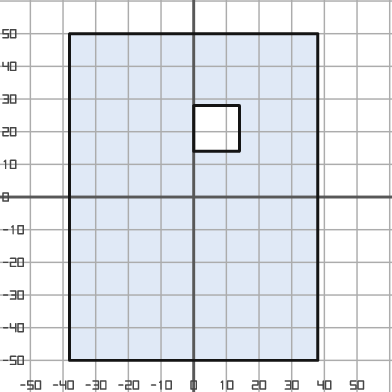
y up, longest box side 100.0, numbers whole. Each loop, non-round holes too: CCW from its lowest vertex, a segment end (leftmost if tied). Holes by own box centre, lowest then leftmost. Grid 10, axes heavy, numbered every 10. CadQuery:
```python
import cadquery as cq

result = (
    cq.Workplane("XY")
    .moveTo(-38.0, -50.0)
    .lineTo(38.0, -50.0)
    .lineTo(38.0, 50.0)
    .lineTo(-38.0, 50.0)
    .close()
    .moveTo(0.0, 14.0)
    .lineTo(14.0, 14.0)
    .lineTo(14.0, 28.0)
    .lineTo(0.0, 28.0)
    .close()
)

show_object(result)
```